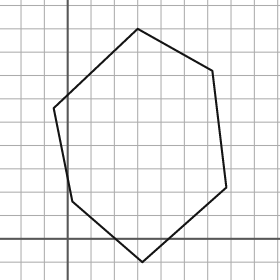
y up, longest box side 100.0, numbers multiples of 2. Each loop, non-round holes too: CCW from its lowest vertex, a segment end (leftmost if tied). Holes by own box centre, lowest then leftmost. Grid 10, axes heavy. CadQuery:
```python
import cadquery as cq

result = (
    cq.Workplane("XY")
    .moveTo(32.0, -10.0)
    .lineTo(68.0, 22.0)
    .lineTo(62.0, 72.0)
    .lineTo(30.0, 90.0)
    .lineTo(-6.0, 56.0)
    .lineTo(2.0, 16.0)
    .close()
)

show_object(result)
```